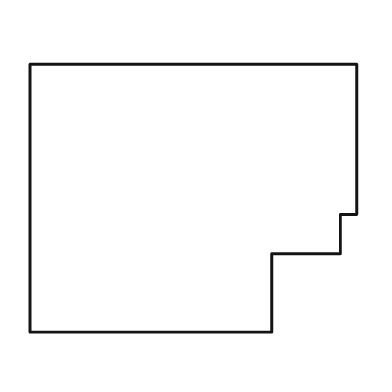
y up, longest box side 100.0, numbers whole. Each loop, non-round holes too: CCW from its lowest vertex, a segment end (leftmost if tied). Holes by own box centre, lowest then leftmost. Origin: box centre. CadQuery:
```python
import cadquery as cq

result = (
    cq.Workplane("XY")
    .moveTo(-50.0, -41.0)
    .lineTo(24.0, -41.0)
    .lineTo(24.0, -17.0)
    .lineTo(45.0, -17.0)
    .lineTo(45.0, -5.0)
    .lineTo(50.0, -5.0)
    .lineTo(50.0, 41.0)
    .lineTo(-50.0, 41.0)
    .close()
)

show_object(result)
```